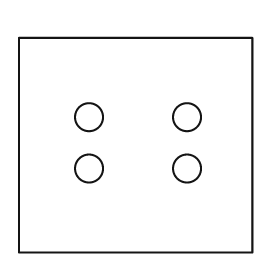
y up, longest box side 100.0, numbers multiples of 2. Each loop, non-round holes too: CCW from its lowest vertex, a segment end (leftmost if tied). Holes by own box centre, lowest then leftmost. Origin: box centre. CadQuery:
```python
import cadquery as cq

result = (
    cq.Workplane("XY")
    .moveTo(-50.0, -46.0)
    .lineTo(50.0, -46.0)
    .lineTo(50.0, 46.0)
    .lineTo(-50.0, 46.0)
    .close()
    .moveTo(-20.0, -10.0)
    .circle(6.0)
    .moveTo(22.0, -10.0)
    .circle(6.0)
    .moveTo(-20.0, 12.0)
    .circle(6.0)
    .moveTo(22.0, 12.0)
    .circle(6.0)
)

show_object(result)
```